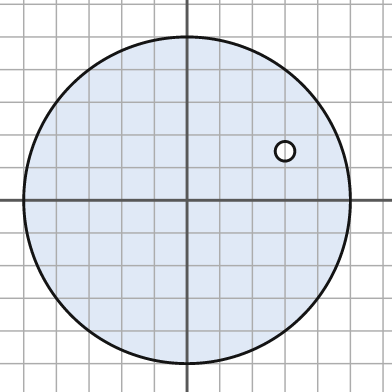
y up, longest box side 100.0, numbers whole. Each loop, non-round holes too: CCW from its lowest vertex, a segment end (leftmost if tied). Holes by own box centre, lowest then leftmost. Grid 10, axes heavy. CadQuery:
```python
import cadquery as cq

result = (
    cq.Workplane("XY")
    .moveTo(0.0, 0.0)
    .circle(50.0)
    .moveTo(30.0, 15.0)
    .circle(3.0)
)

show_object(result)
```